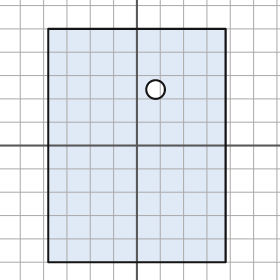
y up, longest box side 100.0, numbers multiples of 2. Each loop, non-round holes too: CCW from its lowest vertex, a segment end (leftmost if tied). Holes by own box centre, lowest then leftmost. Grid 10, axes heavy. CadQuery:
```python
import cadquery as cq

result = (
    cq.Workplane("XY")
    .moveTo(-38.0, -50.0)
    .lineTo(38.0, -50.0)
    .lineTo(38.0, 50.0)
    .lineTo(-38.0, 50.0)
    .close()
    .moveTo(8.0, 24.0)
    .circle(4.0)
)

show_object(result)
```